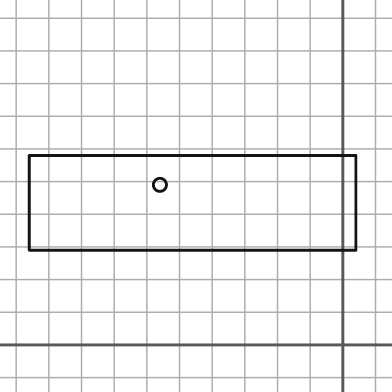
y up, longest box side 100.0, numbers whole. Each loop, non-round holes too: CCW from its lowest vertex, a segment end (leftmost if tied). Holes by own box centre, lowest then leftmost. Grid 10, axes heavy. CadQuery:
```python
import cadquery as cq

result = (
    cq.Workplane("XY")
    .moveTo(-96.0, 29.0)
    .lineTo(4.0, 29.0)
    .lineTo(4.0, 58.0)
    .lineTo(-96.0, 58.0)
    .close()
    .moveTo(-56.0, 49.0)
    .circle(2.0)
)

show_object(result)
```